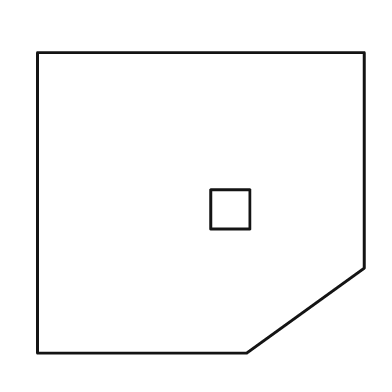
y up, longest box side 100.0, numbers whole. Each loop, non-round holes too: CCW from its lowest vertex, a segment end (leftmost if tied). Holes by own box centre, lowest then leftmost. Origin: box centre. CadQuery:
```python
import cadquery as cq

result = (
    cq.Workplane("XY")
    .moveTo(-50.0, -46.0)
    .lineTo(14.0, -46.0)
    .lineTo(50.0, -20.0)
    .lineTo(50.0, 46.0)
    .lineTo(-50.0, 46.0)
    .close()
    .moveTo(3.0, -8.0)
    .lineTo(15.0, -8.0)
    .lineTo(15.0, 4.0)
    .lineTo(3.0, 4.0)
    .close()
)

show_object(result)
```